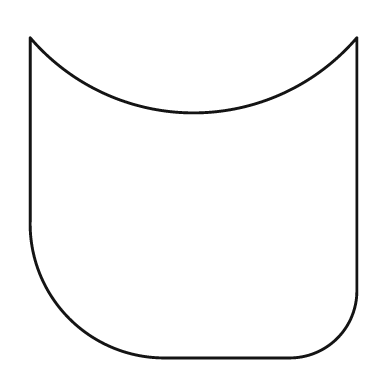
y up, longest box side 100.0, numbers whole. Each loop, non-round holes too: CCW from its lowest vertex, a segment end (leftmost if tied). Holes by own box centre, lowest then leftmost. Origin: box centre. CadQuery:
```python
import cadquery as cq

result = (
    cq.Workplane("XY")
    .moveTo(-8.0, -49.0)
    .lineTo(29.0, -49.0)
    .threePointArc((44.0, -43.0), (50.0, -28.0))
    .lineTo(50.0, 49.0)
    .threePointArc((0.0, 26.0), (-50.0, 49.0))
    .lineTo(-50.0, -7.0)
    .threePointArc((-38.0, -37.0), (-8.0, -49.0))
    .close()
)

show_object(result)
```